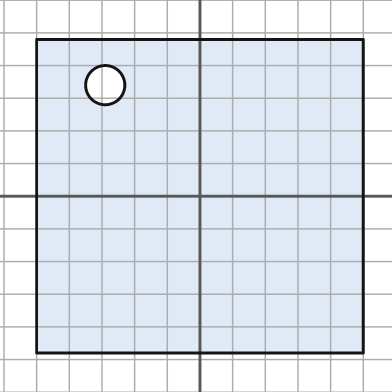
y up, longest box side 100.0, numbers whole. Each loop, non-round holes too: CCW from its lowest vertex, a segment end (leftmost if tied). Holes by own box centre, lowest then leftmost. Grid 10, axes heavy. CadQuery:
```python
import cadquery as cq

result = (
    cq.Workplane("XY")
    .moveTo(-50.0, -48.0)
    .lineTo(50.0, -48.0)
    .lineTo(50.0, 48.0)
    .lineTo(-50.0, 48.0)
    .close()
    .moveTo(-29.0, 34.0)
    .circle(6.0)
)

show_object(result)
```